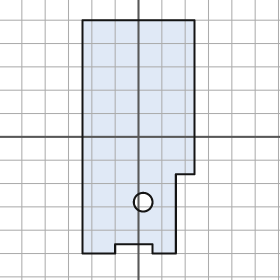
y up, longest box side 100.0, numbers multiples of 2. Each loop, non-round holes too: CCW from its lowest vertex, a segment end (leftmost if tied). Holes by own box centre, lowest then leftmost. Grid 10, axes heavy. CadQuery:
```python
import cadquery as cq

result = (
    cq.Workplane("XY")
    .moveTo(-24.0, -50.0)
    .lineTo(-10.0, -50.0)
    .lineTo(-10.0, -46.0)
    .lineTo(6.0, -46.0)
    .lineTo(6.0, -50.0)
    .lineTo(16.0, -50.0)
    .lineTo(16.0, -16.0)
    .lineTo(24.0, -16.0)
    .lineTo(24.0, 50.0)
    .lineTo(-24.0, 50.0)
    .close()
    .moveTo(2.0, -28.0)
    .circle(4.0)
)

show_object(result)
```